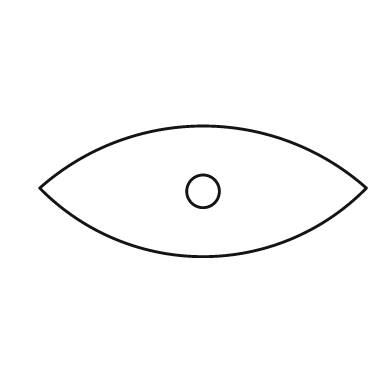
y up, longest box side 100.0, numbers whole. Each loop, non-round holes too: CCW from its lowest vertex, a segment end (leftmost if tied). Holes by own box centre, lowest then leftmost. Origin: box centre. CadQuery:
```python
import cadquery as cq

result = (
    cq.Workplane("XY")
    .moveTo(-50.0, 1.0)
    .threePointArc((0.0, -20.0), (50.0, 1.0))
    .threePointArc((0.0, 20.0), (-50.0, 1.0))
    .close()
    .moveTo(0.0, 0.0)
    .circle(5.0)
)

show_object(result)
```